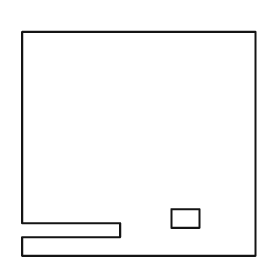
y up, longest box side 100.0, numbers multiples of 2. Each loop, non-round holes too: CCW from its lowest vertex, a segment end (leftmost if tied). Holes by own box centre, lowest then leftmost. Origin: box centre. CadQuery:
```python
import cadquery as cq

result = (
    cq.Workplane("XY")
    .moveTo(-50.0, -48.0)
    .lineTo(50.0, -48.0)
    .lineTo(50.0, 48.0)
    .lineTo(-50.0, 48.0)
    .lineTo(-50.0, -34.0)
    .lineTo(-8.0, -34.0)
    .lineTo(-8.0, -40.0)
    .lineTo(-50.0, -40.0)
    .close()
    .moveTo(14.0, -36.0)
    .lineTo(26.0, -36.0)
    .lineTo(26.0, -28.0)
    .lineTo(14.0, -28.0)
    .close()
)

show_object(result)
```